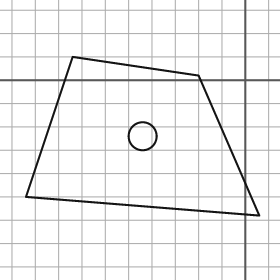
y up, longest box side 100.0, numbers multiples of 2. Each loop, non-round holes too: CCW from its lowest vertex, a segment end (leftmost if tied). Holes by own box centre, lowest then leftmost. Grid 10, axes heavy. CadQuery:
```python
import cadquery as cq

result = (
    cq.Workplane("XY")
    .moveTo(6.0, -58.0)
    .lineTo(-20.0, 2.0)
    .lineTo(-74.0, 10.0)
    .lineTo(-94.0, -50.0)
    .close()
    .moveTo(-44.0, -24.0)
    .circle(6.0)
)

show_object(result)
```